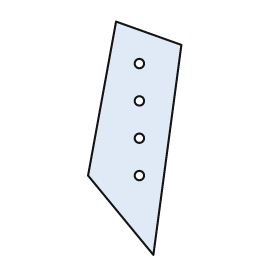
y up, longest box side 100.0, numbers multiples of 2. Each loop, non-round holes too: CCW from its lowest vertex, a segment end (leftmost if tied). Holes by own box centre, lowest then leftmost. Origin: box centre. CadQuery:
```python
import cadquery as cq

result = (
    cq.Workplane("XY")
    .moveTo(8.0, -50.0)
    .lineTo(20.0, 40.0)
    .lineTo(-8.0, 50.0)
    .lineTo(-20.0, -16.0)
    .close()
    .moveTo(2.0, -16.0)
    .circle(2.0)
    .moveTo(2.0, 0.0)
    .circle(2.0)
    .moveTo(2.0, 16.0)
    .circle(2.0)
    .moveTo(2.0, 32.0)
    .circle(2.0)
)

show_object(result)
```